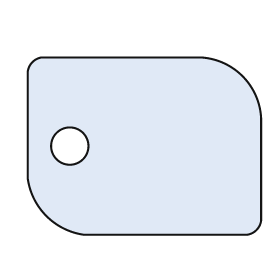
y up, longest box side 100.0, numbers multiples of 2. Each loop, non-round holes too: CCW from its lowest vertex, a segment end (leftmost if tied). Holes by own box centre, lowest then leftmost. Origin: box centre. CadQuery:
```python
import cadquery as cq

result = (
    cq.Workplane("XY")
    .moveTo(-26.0, -38.0)
    .lineTo(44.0, -38.0)
    .threePointArc((48.0, -36.0), (50.0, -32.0))
    .lineTo(50.0, 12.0)
    .threePointArc((42.0, 30.0), (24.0, 38.0))
    .lineTo(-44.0, 38.0)
    .threePointArc((-48.0, 36.0), (-50.0, 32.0))
    .lineTo(-50.0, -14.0)
    .threePointArc((-42.0, -30.0), (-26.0, -38.0))
    .close()
    .moveTo(-32.0, 0.0)
    .circle(8.0)
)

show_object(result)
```